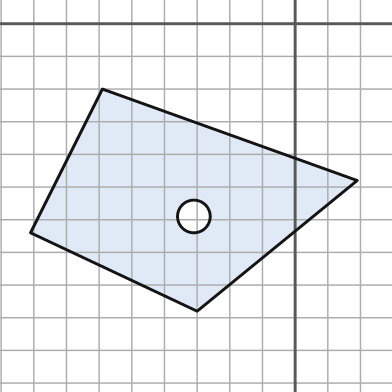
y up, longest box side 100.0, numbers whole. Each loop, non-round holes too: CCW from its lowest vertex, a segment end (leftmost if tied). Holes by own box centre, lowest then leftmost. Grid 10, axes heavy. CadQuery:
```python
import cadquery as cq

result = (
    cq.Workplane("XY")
    .moveTo(-30.0, -88.0)
    .lineTo(19.0, -48.0)
    .lineTo(-59.0, -20.0)
    .lineTo(-81.0, -64.0)
    .close()
    .moveTo(-31.0, -59.0)
    .circle(5.0)
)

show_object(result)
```